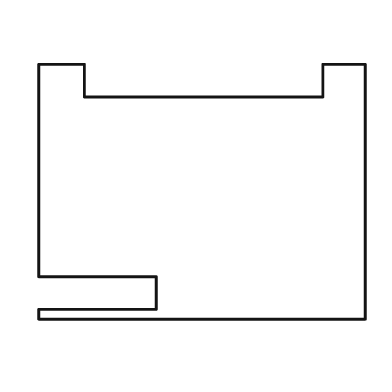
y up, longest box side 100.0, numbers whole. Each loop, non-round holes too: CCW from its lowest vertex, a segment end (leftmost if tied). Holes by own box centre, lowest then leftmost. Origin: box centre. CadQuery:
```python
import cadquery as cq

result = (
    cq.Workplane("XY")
    .moveTo(-50.0, -39.0)
    .lineTo(50.0, -39.0)
    .lineTo(50.0, 39.0)
    .lineTo(37.0, 39.0)
    .lineTo(37.0, 29.0)
    .lineTo(-36.0, 29.0)
    .lineTo(-36.0, 39.0)
    .lineTo(-50.0, 39.0)
    .lineTo(-50.0, -26.0)
    .lineTo(-14.0, -26.0)
    .lineTo(-14.0, -36.0)
    .lineTo(-50.0, -36.0)
    .close()
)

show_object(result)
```